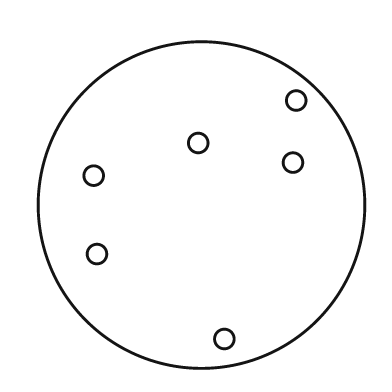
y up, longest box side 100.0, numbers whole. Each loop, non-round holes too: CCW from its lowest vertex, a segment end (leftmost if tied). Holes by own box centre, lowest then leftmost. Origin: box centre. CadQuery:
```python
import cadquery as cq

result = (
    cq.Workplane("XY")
    .moveTo(0.0, 0.0)
    .circle(50.0)
    .moveTo(7.0, -41.0)
    .circle(3.0)
    .moveTo(-32.0, -15.0)
    .circle(3.0)
    .moveTo(-33.0, 9.0)
    .circle(3.0)
    .moveTo(28.0, 13.0)
    .circle(3.0)
    .moveTo(-1.0, 19.0)
    .circle(3.0)
    .moveTo(29.0, 32.0)
    .circle(3.0)
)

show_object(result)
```